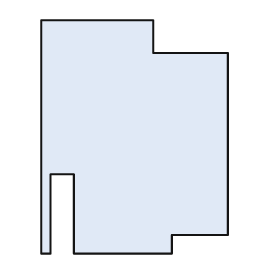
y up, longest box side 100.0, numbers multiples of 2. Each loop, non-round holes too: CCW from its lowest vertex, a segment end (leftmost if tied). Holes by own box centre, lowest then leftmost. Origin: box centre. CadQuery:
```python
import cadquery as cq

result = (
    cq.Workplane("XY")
    .moveTo(-40.0, -50.0)
    .lineTo(-36.0, -50.0)
    .lineTo(-36.0, -16.0)
    .lineTo(-26.0, -16.0)
    .lineTo(-26.0, -50.0)
    .lineTo(16.0, -50.0)
    .lineTo(16.0, -42.0)
    .lineTo(40.0, -42.0)
    .lineTo(40.0, 36.0)
    .lineTo(8.0, 36.0)
    .lineTo(8.0, 50.0)
    .lineTo(-40.0, 50.0)
    .close()
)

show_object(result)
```